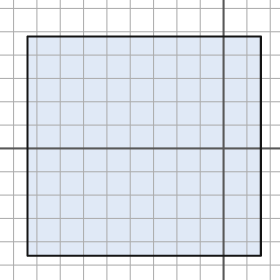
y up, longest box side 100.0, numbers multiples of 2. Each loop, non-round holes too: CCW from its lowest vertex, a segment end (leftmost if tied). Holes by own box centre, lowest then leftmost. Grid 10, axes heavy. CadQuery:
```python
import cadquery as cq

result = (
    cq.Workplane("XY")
    .moveTo(-84.0, -46.0)
    .lineTo(16.0, -46.0)
    .lineTo(16.0, 48.0)
    .lineTo(-84.0, 48.0)
    .close()
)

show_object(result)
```